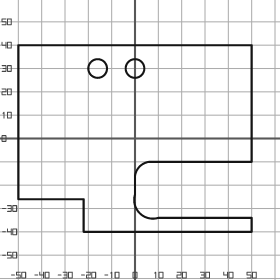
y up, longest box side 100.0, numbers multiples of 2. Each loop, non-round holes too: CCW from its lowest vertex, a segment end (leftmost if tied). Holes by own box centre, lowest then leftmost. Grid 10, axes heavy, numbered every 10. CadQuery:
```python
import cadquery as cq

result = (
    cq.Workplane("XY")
    .moveTo(-22.0, -40.0)
    .lineTo(50.0, -40.0)
    .lineTo(50.0, -34.0)
    .lineTo(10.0, -34.0)
    .threePointArc((2.0, -32.0), (0.0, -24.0))
    .lineTo(0.0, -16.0)
    .threePointArc((2.0, -12.0), (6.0, -10.0))
    .lineTo(50.0, -10.0)
    .lineTo(50.0, 40.0)
    .lineTo(-50.0, 40.0)
    .lineTo(-50.0, -26.0)
    .lineTo(-22.0, -26.0)
    .close()
    .moveTo(-16.0, 30.0)
    .circle(4.0)
    .moveTo(0.0, 30.0)
    .circle(4.0)
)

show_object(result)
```